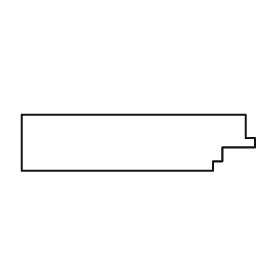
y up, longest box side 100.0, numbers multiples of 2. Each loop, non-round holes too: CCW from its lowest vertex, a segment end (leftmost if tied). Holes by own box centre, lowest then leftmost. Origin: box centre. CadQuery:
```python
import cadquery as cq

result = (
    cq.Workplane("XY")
    .moveTo(-50.0, -12.0)
    .lineTo(32.0, -12.0)
    .lineTo(32.0, -8.0)
    .lineTo(36.0, -8.0)
    .lineTo(36.0, -2.0)
    .lineTo(50.0, -2.0)
    .lineTo(50.0, 2.0)
    .lineTo(46.0, 2.0)
    .lineTo(46.0, 12.0)
    .lineTo(-50.0, 12.0)
    .close()
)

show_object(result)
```